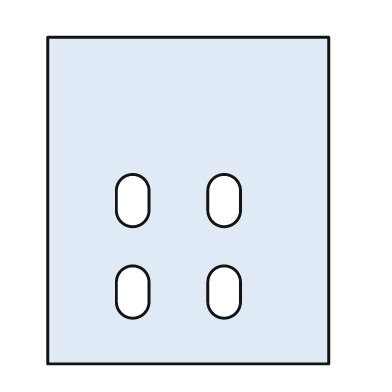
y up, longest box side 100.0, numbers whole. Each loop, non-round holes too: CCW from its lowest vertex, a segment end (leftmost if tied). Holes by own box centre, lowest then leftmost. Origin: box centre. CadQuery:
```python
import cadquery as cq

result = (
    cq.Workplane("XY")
    .moveTo(-43.0, -50.0)
    .lineTo(43.0, -50.0)
    .lineTo(43.0, 50.0)
    .lineTo(-43.0, 50.0)
    .close()
    .moveTo(-22.0, -31.0)
    .threePointArc((-17.0, -36.0), (-12.0, -31.0))
    .lineTo(-12.0, -25.0)
    .threePointArc((-17.0, -20.0), (-22.0, -25.0))
    .close()
    .moveTo(6.0, -31.0)
    .threePointArc((11.0, -36.0), (16.0, -31.0))
    .lineTo(16.0, -25.0)
    .threePointArc((11.0, -20.0), (6.0, -25.0))
    .close()
    .moveTo(-22.0, -3.0)
    .threePointArc((-17.0, -8.0), (-12.0, -3.0))
    .lineTo(-12.0, 3.0)
    .threePointArc((-17.0, 8.0), (-22.0, 3.0))
    .close()
    .moveTo(6.0, -3.0)
    .threePointArc((11.0, -8.0), (16.0, -3.0))
    .lineTo(16.0, 3.0)
    .threePointArc((11.0, 8.0), (6.0, 3.0))
    .close()
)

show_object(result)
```